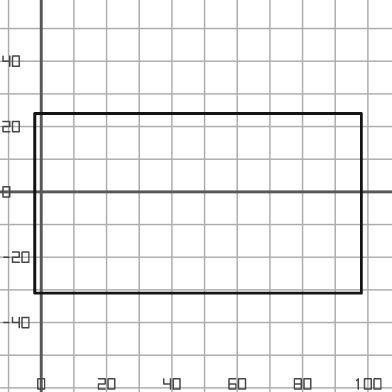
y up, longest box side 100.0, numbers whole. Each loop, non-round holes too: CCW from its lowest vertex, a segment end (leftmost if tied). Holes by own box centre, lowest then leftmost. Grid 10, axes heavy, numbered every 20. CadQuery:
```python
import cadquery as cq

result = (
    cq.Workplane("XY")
    .moveTo(-2.0, -31.0)
    .lineTo(98.0, -31.0)
    .lineTo(98.0, 24.0)
    .lineTo(-2.0, 24.0)
    .close()
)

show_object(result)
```